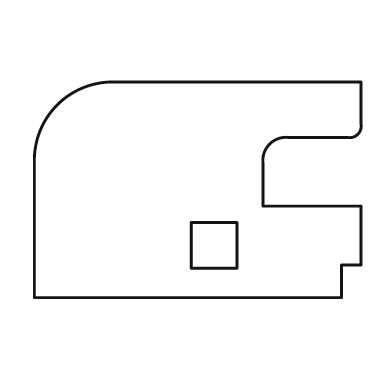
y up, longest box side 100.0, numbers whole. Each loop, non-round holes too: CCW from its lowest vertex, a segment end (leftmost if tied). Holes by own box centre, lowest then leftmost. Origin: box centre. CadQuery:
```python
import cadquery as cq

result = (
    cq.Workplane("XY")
    .moveTo(-50.0, -33.0)
    .lineTo(44.0, -33.0)
    .lineTo(44.0, -23.0)
    .lineTo(50.0, -23.0)
    .lineTo(50.0, -5.0)
    .lineTo(20.0, -5.0)
    .lineTo(20.0, 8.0)
    .threePointArc((22.0, 14.0), (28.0, 16.0))
    .lineTo(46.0, 16.0)
    .threePointArc((49.0, 17.0), (50.0, 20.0))
    .lineTo(50.0, 33.0)
    .lineTo(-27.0, 33.0)
    .threePointArc((-43.0, 26.0), (-50.0, 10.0))
    .close()
    .moveTo(-2.0, -24.0)
    .lineTo(12.0, -24.0)
    .lineTo(12.0, -10.0)
    .lineTo(-2.0, -10.0)
    .close()
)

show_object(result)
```